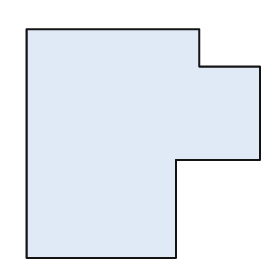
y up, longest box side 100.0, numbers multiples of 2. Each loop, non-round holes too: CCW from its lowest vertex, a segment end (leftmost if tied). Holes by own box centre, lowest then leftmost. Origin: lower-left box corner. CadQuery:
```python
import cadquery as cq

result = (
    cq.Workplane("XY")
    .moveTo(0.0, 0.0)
    .lineTo(64.0, 0.0)
    .lineTo(64.0, 42.0)
    .lineTo(100.0, 42.0)
    .lineTo(100.0, 82.0)
    .lineTo(74.0, 82.0)
    .lineTo(74.0, 98.0)
    .lineTo(0.0, 98.0)
    .close()
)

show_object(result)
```